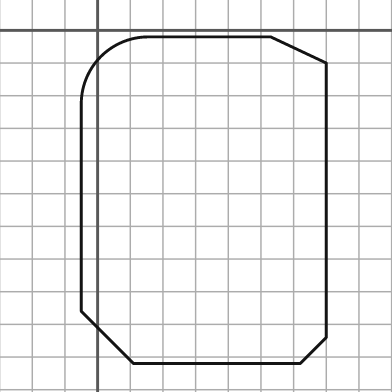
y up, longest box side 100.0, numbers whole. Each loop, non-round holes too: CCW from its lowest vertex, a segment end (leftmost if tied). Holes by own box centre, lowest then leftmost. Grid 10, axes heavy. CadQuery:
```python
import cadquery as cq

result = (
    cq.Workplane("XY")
    .moveTo(11.0, -102.0)
    .lineTo(62.0, -102.0)
    .lineTo(70.0, -94.0)
    .lineTo(70.0, -10.0)
    .lineTo(53.0, -2.0)
    .lineTo(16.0, -2.0)
    .threePointArc((1.0, -8.0), (-5.0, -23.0))
    .lineTo(-5.0, -86.0)
    .close()
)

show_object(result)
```